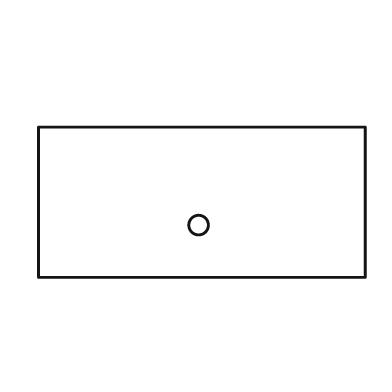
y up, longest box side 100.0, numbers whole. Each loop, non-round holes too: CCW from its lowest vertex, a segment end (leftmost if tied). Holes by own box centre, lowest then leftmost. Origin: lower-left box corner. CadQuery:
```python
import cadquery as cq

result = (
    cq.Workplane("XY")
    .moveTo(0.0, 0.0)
    .lineTo(100.0, 0.0)
    .lineTo(100.0, 46.0)
    .lineTo(0.0, 46.0)
    .close()
    .moveTo(49.0, 16.0)
    .circle(3.0)
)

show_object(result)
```